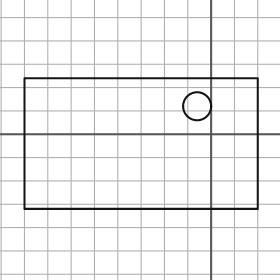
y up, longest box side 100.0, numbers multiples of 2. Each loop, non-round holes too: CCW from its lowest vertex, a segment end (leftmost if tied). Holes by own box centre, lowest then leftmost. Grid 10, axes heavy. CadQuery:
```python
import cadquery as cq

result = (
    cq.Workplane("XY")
    .moveTo(-80.0, -32.0)
    .lineTo(20.0, -32.0)
    .lineTo(20.0, 24.0)
    .lineTo(-80.0, 24.0)
    .close()
    .moveTo(-6.0, 12.0)
    .circle(6.0)
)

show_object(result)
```